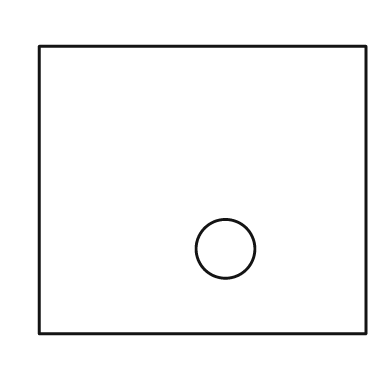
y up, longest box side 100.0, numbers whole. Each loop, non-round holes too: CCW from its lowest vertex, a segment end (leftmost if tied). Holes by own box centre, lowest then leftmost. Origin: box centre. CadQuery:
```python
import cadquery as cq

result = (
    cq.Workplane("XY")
    .moveTo(-50.0, -44.0)
    .lineTo(50.0, -44.0)
    .lineTo(50.0, 44.0)
    .lineTo(-50.0, 44.0)
    .close()
    .moveTo(7.0, -18.0)
    .circle(9.0)
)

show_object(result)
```